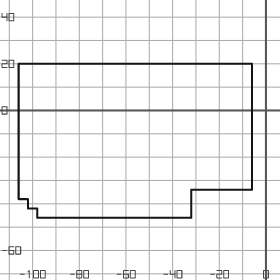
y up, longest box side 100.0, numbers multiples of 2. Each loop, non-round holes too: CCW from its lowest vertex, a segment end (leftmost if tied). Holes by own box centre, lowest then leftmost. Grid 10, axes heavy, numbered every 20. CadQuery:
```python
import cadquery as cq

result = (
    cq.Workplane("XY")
    .moveTo(-98.0, -46.0)
    .lineTo(-32.0, -46.0)
    .lineTo(-32.0, -34.0)
    .lineTo(-6.0, -34.0)
    .lineTo(-6.0, 20.0)
    .lineTo(-106.0, 20.0)
    .lineTo(-106.0, -38.0)
    .lineTo(-102.0, -38.0)
    .lineTo(-102.0, -42.0)
    .lineTo(-98.0, -42.0)
    .close()
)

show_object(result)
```